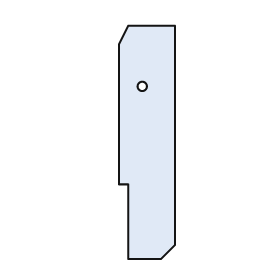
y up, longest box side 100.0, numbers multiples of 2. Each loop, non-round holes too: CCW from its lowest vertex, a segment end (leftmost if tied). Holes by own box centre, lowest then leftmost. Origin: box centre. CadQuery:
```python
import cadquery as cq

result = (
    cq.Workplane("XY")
    .moveTo(-8.0, -50.0)
    .lineTo(6.0, -50.0)
    .lineTo(12.0, -44.0)
    .lineTo(12.0, 50.0)
    .lineTo(-8.0, 50.0)
    .lineTo(-12.0, 42.0)
    .lineTo(-12.0, -18.0)
    .lineTo(-8.0, -18.0)
    .close()
    .moveTo(-2.0, 24.0)
    .circle(2.0)
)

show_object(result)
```